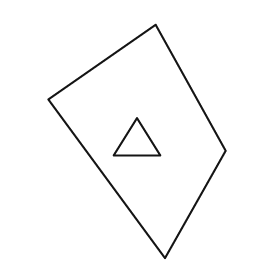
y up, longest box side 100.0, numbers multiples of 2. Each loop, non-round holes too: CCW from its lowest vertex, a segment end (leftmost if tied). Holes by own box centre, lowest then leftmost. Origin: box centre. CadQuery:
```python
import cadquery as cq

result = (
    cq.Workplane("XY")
    .moveTo(12.0, -50.0)
    .lineTo(38.0, -4.0)
    .lineTo(8.0, 50.0)
    .lineTo(-38.0, 18.0)
    .close()
    .moveTo(-10.0, -6.0)
    .lineTo(10.0, -6.0)
    .lineTo(0.0, 10.0)
    .close()
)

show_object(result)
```